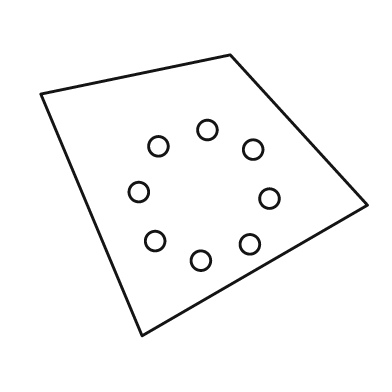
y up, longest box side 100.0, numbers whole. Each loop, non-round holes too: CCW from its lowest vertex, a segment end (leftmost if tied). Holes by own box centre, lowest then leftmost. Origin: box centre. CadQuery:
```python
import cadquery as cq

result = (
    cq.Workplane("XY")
    .moveTo(-19.0, -43.0)
    .lineTo(50.0, -3.0)
    .lineTo(8.0, 43.0)
    .lineTo(-50.0, 31.0)
    .close()
    .moveTo(-1.0, -20.0)
    .circle(3.0)
    .moveTo(14.0, -15.0)
    .circle(3.0)
    .moveTo(-15.0, -14.0)
    .circle(3.0)
    .moveTo(20.0, -1.0)
    .circle(3.0)
    .moveTo(-20.0, 1.0)
    .circle(3.0)
    .moveTo(15.0, 14.0)
    .circle(3.0)
    .moveTo(-14.0, 15.0)
    .circle(3.0)
    .moveTo(1.0, 20.0)
    .circle(3.0)
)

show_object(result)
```